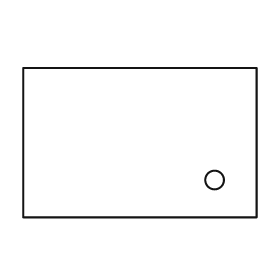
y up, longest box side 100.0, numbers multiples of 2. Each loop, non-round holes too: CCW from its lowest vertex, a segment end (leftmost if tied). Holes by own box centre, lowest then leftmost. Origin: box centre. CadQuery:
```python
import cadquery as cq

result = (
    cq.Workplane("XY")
    .moveTo(-50.0, -32.0)
    .lineTo(50.0, -32.0)
    .lineTo(50.0, 32.0)
    .lineTo(-50.0, 32.0)
    .close()
    .moveTo(32.0, -16.0)
    .circle(4.0)
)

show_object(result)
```